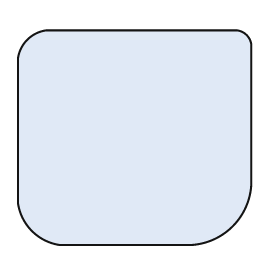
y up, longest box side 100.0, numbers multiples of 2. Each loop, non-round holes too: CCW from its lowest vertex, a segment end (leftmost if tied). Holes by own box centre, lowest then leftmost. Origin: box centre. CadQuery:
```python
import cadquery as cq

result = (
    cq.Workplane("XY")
    .moveTo(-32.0, -46.0)
    .lineTo(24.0, -46.0)
    .threePointArc((42.0, -38.0), (50.0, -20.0))
    .lineTo(50.0, 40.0)
    .threePointArc((48.0, 44.0), (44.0, 46.0))
    .lineTo(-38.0, 46.0)
    .threePointArc((-46.0, 42.0), (-50.0, 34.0))
    .lineTo(-50.0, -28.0)
    .threePointArc((-44.0, -40.0), (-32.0, -46.0))
    .close()
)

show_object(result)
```